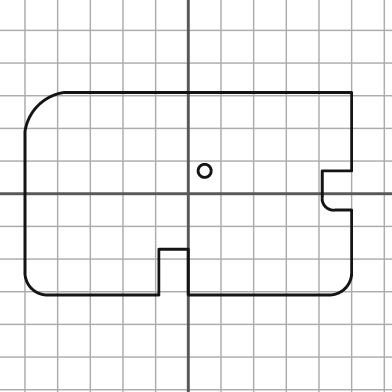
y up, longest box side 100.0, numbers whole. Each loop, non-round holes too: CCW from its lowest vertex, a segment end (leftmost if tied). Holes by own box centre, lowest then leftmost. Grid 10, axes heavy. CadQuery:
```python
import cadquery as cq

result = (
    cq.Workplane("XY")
    .moveTo(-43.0, -31.0)
    .lineTo(-9.0, -31.0)
    .lineTo(-9.0, -17.0)
    .lineTo(0.0, -17.0)
    .lineTo(0.0, -31.0)
    .lineTo(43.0, -31.0)
    .threePointArc((48.0, -29.0), (50.0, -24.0))
    .lineTo(50.0, -5.0)
    .lineTo(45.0, -5.0)
    .threePointArc((42.0, -4.0), (41.0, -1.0))
    .lineTo(41.0, 7.0)
    .lineTo(50.0, 7.0)
    .lineTo(50.0, 31.0)
    .lineTo(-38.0, 31.0)
    .threePointArc((-46.0, 27.0), (-50.0, 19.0))
    .lineTo(-50.0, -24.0)
    .threePointArc((-48.0, -29.0), (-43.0, -31.0))
    .close()
    .moveTo(5.0, 7.0)
    .circle(2.0)
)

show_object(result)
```